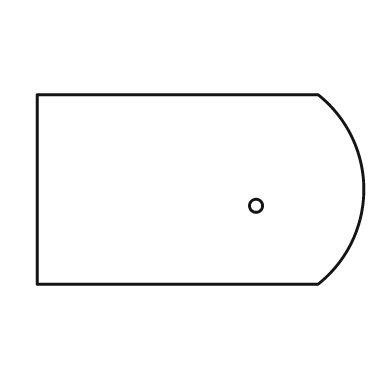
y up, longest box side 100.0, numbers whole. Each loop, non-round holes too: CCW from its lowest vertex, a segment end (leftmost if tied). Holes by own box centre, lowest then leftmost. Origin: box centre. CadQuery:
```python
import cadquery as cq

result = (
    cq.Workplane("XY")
    .moveTo(-50.0, -29.0)
    .lineTo(36.0, -29.0)
    .threePointArc((50.0, 0.0), (36.0, 29.0))
    .lineTo(-50.0, 29.0)
    .close()
    .moveTo(17.0, -5.0)
    .circle(2.0)
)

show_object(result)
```